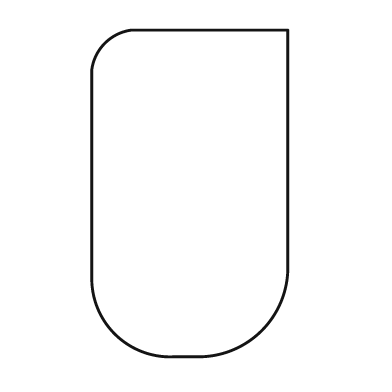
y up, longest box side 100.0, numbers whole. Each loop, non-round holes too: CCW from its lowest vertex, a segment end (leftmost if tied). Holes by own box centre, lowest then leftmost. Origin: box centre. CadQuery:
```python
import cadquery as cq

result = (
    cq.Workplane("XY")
    .moveTo(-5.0, -50.0)
    .lineTo(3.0, -50.0)
    .threePointArc((22.0, -42.0), (30.0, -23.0))
    .lineTo(30.0, 50.0)
    .lineTo(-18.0, 50.0)
    .threePointArc((-26.0, 46.0), (-30.0, 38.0))
    .lineTo(-30.0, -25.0)
    .threePointArc((-23.0, -43.0), (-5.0, -50.0))
    .close()
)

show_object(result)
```